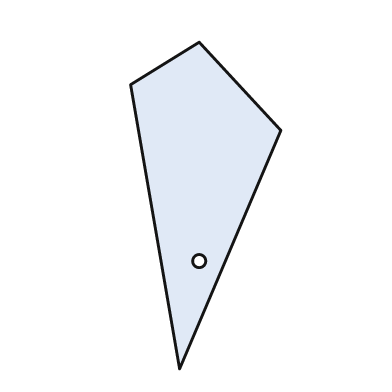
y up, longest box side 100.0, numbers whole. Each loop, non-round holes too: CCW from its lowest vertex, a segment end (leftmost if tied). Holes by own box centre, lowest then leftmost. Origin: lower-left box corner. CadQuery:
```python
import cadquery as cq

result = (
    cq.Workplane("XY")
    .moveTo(15.0, 0.0)
    .lineTo(46.0, 73.0)
    .lineTo(21.0, 100.0)
    .lineTo(0.0, 87.0)
    .close()
    .moveTo(21.0, 33.0)
    .circle(2.0)
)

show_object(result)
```